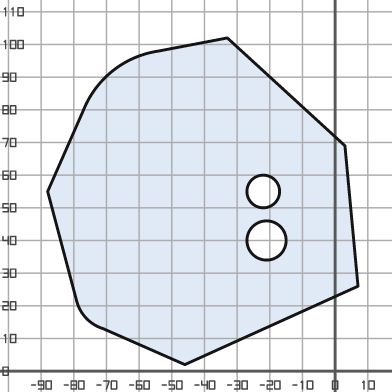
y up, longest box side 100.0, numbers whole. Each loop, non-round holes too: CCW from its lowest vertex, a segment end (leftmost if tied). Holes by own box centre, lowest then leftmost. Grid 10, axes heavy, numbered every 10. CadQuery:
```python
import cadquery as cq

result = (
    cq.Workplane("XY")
    .moveTo(-46.0, 2.0)
    .lineTo(7.0, 26.0)
    .lineTo(3.0, 69.0)
    .lineTo(-33.0, 102.0)
    .lineTo(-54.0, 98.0)
    .threePointArc((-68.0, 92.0), (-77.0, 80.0))
    .lineTo(-88.0, 55.0)
    .lineTo(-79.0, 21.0)
    .threePointArc((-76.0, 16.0), (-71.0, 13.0))
    .close()
    .moveTo(-21.0, 40.0)
    .circle(6.0)
    .moveTo(-22.0, 55.0)
    .circle(5.0)
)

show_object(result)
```